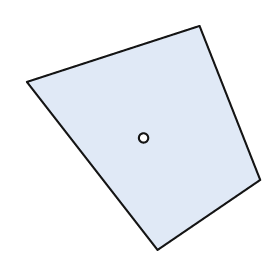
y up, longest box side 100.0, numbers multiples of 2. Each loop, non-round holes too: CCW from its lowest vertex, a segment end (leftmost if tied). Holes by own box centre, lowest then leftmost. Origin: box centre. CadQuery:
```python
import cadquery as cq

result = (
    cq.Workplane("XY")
    .moveTo(6.0, -48.0)
    .lineTo(50.0, -18.0)
    .lineTo(24.0, 48.0)
    .lineTo(-50.0, 24.0)
    .close()
    .moveTo(0.0, 0.0)
    .circle(2.0)
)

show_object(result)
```